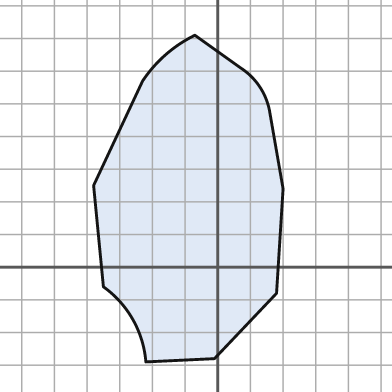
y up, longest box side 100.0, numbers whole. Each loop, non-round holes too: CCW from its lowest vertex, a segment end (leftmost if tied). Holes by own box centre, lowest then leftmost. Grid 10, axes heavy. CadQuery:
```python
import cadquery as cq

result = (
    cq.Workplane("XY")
    .moveTo(-22.0, -29.0)
    .lineTo(-1.0, -28.0)
    .lineTo(18.0, -8.0)
    .lineTo(20.0, 24.0)
    .lineTo(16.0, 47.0)
    .threePointArc((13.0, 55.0), (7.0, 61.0))
    .lineTo(-7.0, 71.0)
    .threePointArc((-16.0, 65.0), (-23.0, 57.0))
    .lineTo(-38.0, 25.0)
    .lineTo(-35.0, -6.0)
    .threePointArc((-26.0, -16.0), (-22.0, -29.0))
    .close()
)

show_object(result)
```